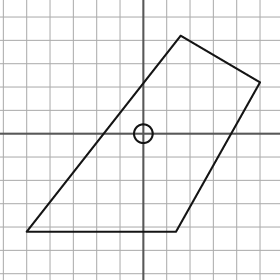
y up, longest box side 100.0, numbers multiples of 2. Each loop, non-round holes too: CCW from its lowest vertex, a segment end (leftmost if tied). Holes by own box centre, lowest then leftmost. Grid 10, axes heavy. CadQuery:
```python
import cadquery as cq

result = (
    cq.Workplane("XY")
    .moveTo(-50.0, -42.0)
    .lineTo(14.0, -42.0)
    .lineTo(50.0, 22.0)
    .lineTo(16.0, 42.0)
    .close()
    .moveTo(0.0, 0.0)
    .circle(4.0)
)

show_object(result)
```